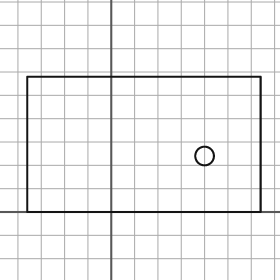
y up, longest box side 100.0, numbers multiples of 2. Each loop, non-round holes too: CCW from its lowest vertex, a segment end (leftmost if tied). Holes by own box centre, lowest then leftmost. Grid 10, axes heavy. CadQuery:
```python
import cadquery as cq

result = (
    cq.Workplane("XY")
    .moveTo(-36.0, 0.0)
    .lineTo(64.0, 0.0)
    .lineTo(64.0, 58.0)
    .lineTo(-36.0, 58.0)
    .close()
    .moveTo(40.0, 24.0)
    .circle(4.0)
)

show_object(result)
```